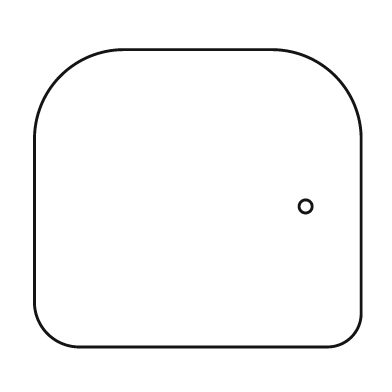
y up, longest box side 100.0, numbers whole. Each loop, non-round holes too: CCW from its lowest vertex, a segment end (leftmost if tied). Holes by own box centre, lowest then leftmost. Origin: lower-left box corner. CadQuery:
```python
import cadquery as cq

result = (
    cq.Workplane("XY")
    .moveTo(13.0, 0.0)
    .lineTo(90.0, 0.0)
    .threePointArc((97.0, 3.0), (100.0, 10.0))
    .lineTo(100.0, 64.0)
    .threePointArc((92.0, 83.0), (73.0, 91.0))
    .lineTo(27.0, 91.0)
    .threePointArc((8.0, 83.0), (0.0, 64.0))
    .lineTo(0.0, 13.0)
    .threePointArc((4.0, 4.0), (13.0, 0.0))
    .close()
    .moveTo(83.0, 43.0)
    .circle(2.0)
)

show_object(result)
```